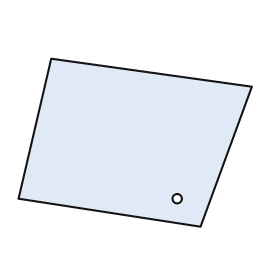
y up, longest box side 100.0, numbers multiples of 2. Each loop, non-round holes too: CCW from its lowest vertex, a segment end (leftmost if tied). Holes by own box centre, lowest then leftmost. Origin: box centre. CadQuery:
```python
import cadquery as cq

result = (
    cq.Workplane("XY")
    .moveTo(28.0, -36.0)
    .lineTo(50.0, 24.0)
    .lineTo(-36.0, 36.0)
    .lineTo(-50.0, -24.0)
    .close()
    .moveTo(18.0, -24.0)
    .circle(2.0)
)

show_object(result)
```